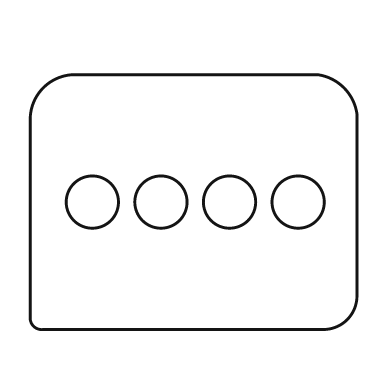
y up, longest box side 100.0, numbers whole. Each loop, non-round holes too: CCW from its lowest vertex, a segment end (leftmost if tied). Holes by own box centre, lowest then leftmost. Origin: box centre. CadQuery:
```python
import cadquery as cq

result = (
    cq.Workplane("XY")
    .moveTo(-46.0, -39.0)
    .lineTo(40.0, -39.0)
    .threePointArc((47.0, -36.0), (50.0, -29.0))
    .lineTo(50.0, 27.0)
    .threePointArc((46.0, 35.0), (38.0, 39.0))
    .lineTo(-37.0, 39.0)
    .threePointArc((-46.0, 35.0), (-50.0, 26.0))
    .lineTo(-50.0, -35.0)
    .threePointArc((-49.0, -38.0), (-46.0, -39.0))
    .close()
    .moveTo(-31.0, 0.0)
    .circle(8.0)
    .moveTo(-10.0, 0.0)
    .circle(8.0)
    .moveTo(11.0, 0.0)
    .circle(8.0)
    .moveTo(32.0, 0.0)
    .circle(8.0)
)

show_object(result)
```